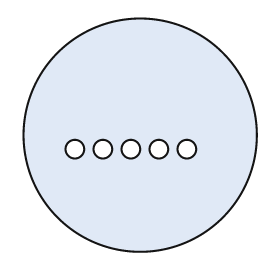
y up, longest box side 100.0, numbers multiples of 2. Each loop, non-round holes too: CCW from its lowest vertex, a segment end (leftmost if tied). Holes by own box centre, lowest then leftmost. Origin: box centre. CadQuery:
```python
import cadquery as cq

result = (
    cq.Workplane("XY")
    .moveTo(0.0, 0.0)
    .circle(50.0)
    .moveTo(-28.0, -6.0)
    .circle(4.0)
    .moveTo(-16.0, -6.0)
    .circle(4.0)
    .moveTo(-4.0, -6.0)
    .circle(4.0)
    .moveTo(8.0, -6.0)
    .circle(4.0)
    .moveTo(20.0, -6.0)
    .circle(4.0)
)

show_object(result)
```